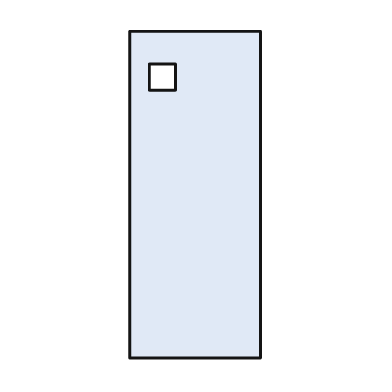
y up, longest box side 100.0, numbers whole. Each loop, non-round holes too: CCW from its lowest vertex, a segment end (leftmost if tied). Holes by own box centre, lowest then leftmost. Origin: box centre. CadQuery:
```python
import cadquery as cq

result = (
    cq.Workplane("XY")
    .moveTo(-20.0, -50.0)
    .lineTo(20.0, -50.0)
    .lineTo(20.0, 50.0)
    .lineTo(-20.0, 50.0)
    .close()
    .moveTo(-14.0, 32.0)
    .lineTo(-6.0, 32.0)
    .lineTo(-6.0, 40.0)
    .lineTo(-14.0, 40.0)
    .close()
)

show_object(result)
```